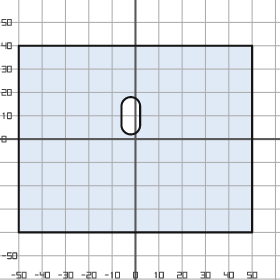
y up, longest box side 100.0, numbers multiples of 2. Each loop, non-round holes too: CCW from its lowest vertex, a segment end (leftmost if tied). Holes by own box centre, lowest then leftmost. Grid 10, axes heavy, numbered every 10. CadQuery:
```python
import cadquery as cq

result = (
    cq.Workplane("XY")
    .moveTo(-50.0, -40.0)
    .lineTo(50.0, -40.0)
    .lineTo(50.0, 40.0)
    .lineTo(-50.0, 40.0)
    .close()
    .moveTo(-6.0, 6.0)
    .threePointArc((-2.0, 2.0), (2.0, 6.0))
    .lineTo(2.0, 14.0)
    .threePointArc((-2.0, 18.0), (-6.0, 14.0))
    .close()
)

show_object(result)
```